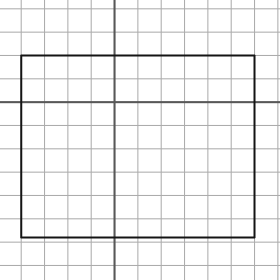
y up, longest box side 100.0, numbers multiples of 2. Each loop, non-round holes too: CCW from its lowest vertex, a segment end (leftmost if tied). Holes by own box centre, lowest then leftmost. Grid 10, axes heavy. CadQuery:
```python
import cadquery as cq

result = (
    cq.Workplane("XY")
    .moveTo(-40.0, -58.0)
    .lineTo(60.0, -58.0)
    .lineTo(60.0, 20.0)
    .lineTo(-40.0, 20.0)
    .close()
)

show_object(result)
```